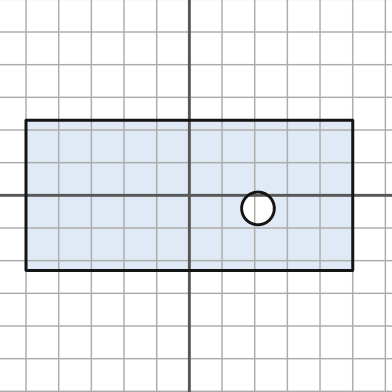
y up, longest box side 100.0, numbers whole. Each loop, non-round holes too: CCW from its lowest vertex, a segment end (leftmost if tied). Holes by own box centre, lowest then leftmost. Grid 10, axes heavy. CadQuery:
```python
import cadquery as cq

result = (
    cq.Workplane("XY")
    .moveTo(-50.0, -23.0)
    .lineTo(50.0, -23.0)
    .lineTo(50.0, 23.0)
    .lineTo(-50.0, 23.0)
    .close()
    .moveTo(21.0, -4.0)
    .circle(5.0)
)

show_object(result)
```